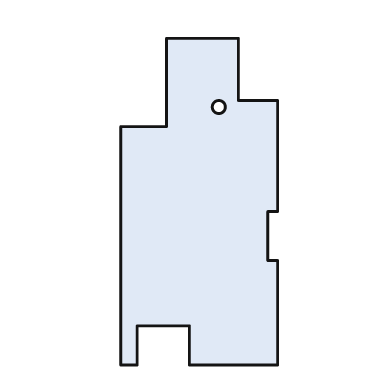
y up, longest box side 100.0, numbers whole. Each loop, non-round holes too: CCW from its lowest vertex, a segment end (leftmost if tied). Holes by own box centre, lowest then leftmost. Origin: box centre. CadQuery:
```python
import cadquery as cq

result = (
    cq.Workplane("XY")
    .moveTo(-24.0, -50.0)
    .lineTo(-19.0, -50.0)
    .lineTo(-19.0, -38.0)
    .lineTo(-3.0, -38.0)
    .lineTo(-3.0, -50.0)
    .lineTo(24.0, -50.0)
    .lineTo(24.0, -18.0)
    .lineTo(21.0, -18.0)
    .lineTo(21.0, -3.0)
    .lineTo(24.0, -3.0)
    .lineTo(24.0, 31.0)
    .lineTo(12.0, 31.0)
    .lineTo(12.0, 50.0)
    .lineTo(-10.0, 50.0)
    .lineTo(-10.0, 23.0)
    .lineTo(-24.0, 23.0)
    .close()
    .moveTo(6.0, 29.0)
    .circle(2.0)
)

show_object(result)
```